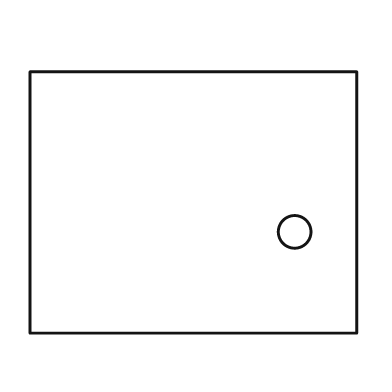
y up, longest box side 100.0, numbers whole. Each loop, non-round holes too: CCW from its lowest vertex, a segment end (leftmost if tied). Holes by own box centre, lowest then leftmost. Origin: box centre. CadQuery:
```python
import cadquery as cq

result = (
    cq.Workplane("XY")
    .moveTo(-50.0, -40.0)
    .lineTo(50.0, -40.0)
    .lineTo(50.0, 40.0)
    .lineTo(-50.0, 40.0)
    .close()
    .moveTo(31.0, -9.0)
    .circle(5.0)
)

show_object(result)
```